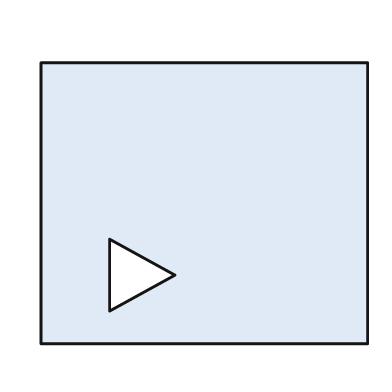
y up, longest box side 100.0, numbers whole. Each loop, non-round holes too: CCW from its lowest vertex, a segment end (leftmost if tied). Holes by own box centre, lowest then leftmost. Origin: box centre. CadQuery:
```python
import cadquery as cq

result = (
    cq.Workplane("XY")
    .moveTo(-50.0, -43.0)
    .lineTo(50.0, -43.0)
    .lineTo(50.0, 43.0)
    .lineTo(-50.0, 43.0)
    .close()
    .moveTo(-29.0, -33.0)
    .lineTo(-9.0, -22.0)
    .lineTo(-29.0, -11.0)
    .close()
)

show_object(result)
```